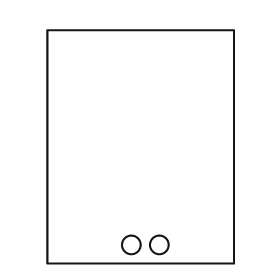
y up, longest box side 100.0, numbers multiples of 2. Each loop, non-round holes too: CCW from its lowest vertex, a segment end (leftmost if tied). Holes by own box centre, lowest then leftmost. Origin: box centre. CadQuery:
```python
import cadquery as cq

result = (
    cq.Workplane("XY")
    .moveTo(-40.0, -50.0)
    .lineTo(40.0, -50.0)
    .lineTo(40.0, 50.0)
    .lineTo(-40.0, 50.0)
    .close()
    .moveTo(-4.0, -42.0)
    .circle(4.0)
    .moveTo(8.0, -42.0)
    .circle(4.0)
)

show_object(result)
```